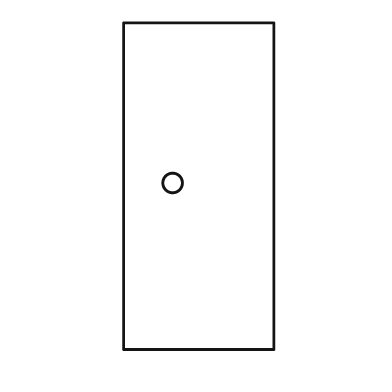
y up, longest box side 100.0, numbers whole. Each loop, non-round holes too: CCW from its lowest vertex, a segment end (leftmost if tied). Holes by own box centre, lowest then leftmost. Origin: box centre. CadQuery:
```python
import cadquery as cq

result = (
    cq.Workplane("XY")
    .moveTo(-23.0, -50.0)
    .lineTo(23.0, -50.0)
    .lineTo(23.0, 50.0)
    .lineTo(-23.0, 50.0)
    .close()
    .moveTo(-8.0, 1.0)
    .circle(3.0)
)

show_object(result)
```